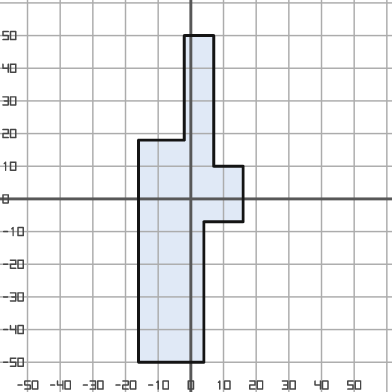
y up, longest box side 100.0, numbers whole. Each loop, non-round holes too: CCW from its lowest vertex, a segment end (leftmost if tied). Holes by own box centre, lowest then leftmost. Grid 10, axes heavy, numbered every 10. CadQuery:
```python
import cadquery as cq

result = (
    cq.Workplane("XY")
    .moveTo(-16.0, -50.0)
    .lineTo(4.0, -50.0)
    .lineTo(4.0, -7.0)
    .lineTo(16.0, -7.0)
    .lineTo(16.0, 10.0)
    .lineTo(7.0, 10.0)
    .lineTo(7.0, 50.0)
    .lineTo(-2.0, 50.0)
    .lineTo(-2.0, 18.0)
    .lineTo(-16.0, 18.0)
    .close()
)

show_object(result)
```